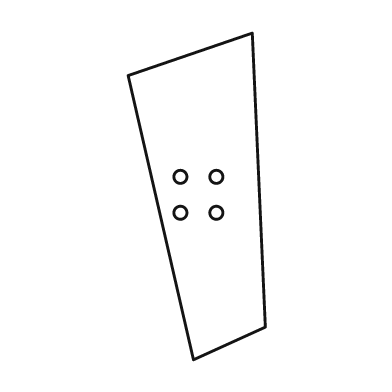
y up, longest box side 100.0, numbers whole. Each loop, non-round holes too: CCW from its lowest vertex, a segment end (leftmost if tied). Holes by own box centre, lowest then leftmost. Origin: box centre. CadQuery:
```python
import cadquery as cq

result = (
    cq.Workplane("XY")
    .moveTo(-1.0, -50.0)
    .lineTo(21.0, -40.0)
    .lineTo(17.0, 50.0)
    .lineTo(-21.0, 37.0)
    .close()
    .moveTo(-5.0, -5.0)
    .circle(2.0)
    .moveTo(6.0, -5.0)
    .circle(2.0)
    .moveTo(-5.0, 6.0)
    .circle(2.0)
    .moveTo(6.0, 6.0)
    .circle(2.0)
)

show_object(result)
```